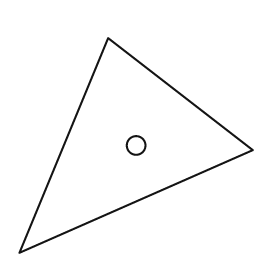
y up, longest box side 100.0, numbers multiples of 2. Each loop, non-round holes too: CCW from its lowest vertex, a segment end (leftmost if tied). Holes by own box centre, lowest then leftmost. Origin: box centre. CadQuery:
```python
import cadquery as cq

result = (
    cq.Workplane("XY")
    .moveTo(-50.0, -46.0)
    .lineTo(50.0, -2.0)
    .lineTo(-12.0, 46.0)
    .close()
    .moveTo(0.0, 0.0)
    .circle(4.0)
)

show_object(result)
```